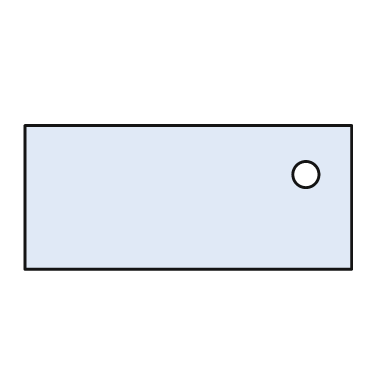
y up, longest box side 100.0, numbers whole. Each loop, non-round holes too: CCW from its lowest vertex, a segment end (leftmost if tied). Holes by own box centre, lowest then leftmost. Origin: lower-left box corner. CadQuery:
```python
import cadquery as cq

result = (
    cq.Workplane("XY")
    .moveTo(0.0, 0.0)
    .lineTo(100.0, 0.0)
    .lineTo(100.0, 44.0)
    .lineTo(0.0, 44.0)
    .close()
    .moveTo(86.0, 29.0)
    .circle(4.0)
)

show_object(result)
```